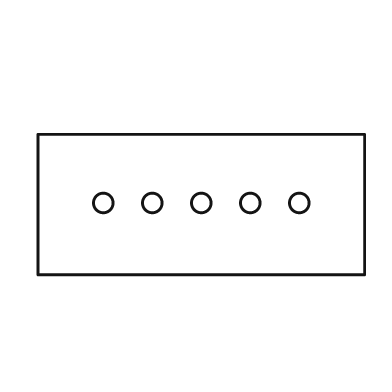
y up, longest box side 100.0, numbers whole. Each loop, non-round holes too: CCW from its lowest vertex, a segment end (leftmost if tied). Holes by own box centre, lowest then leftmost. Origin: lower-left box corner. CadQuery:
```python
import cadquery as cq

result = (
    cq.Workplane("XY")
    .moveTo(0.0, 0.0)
    .lineTo(100.0, 0.0)
    .lineTo(100.0, 43.0)
    .lineTo(0.0, 43.0)
    .close()
    .moveTo(20.0, 22.0)
    .circle(3.0)
    .moveTo(35.0, 22.0)
    .circle(3.0)
    .moveTo(50.0, 22.0)
    .circle(3.0)
    .moveTo(65.0, 22.0)
    .circle(3.0)
    .moveTo(80.0, 22.0)
    .circle(3.0)
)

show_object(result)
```